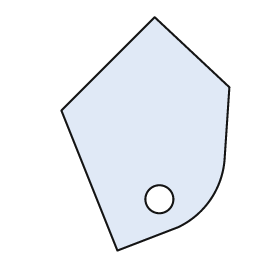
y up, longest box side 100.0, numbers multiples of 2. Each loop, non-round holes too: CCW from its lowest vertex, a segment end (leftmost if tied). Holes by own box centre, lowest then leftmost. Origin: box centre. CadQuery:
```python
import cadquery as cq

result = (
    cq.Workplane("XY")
    .moveTo(-12.0, -50.0)
    .lineTo(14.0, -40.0)
    .threePointArc((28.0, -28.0), (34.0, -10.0))
    .lineTo(36.0, 20.0)
    .lineTo(4.0, 50.0)
    .lineTo(-36.0, 10.0)
    .close()
    .moveTo(6.0, -28.0)
    .circle(6.0)
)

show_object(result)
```